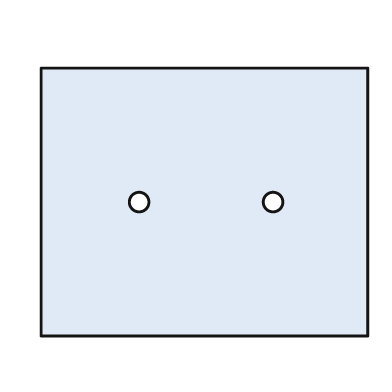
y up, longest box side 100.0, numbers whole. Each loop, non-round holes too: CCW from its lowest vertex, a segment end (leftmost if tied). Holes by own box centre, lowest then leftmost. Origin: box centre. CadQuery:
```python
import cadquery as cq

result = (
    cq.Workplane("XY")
    .moveTo(-50.0, -41.0)
    .lineTo(50.0, -41.0)
    .lineTo(50.0, 41.0)
    .lineTo(-50.0, 41.0)
    .close()
    .moveTo(-20.0, 0.0)
    .circle(3.0)
    .moveTo(21.0, 0.0)
    .circle(3.0)
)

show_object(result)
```